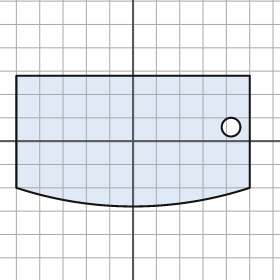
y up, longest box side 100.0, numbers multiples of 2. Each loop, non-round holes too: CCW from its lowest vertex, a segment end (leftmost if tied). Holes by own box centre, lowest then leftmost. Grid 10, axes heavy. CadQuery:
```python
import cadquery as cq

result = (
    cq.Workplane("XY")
    .moveTo(-50.0, -20.0)
    .threePointArc((0.0, -28.0), (50.0, -20.0))
    .lineTo(50.0, 28.0)
    .lineTo(-50.0, 28.0)
    .close()
    .moveTo(42.0, 6.0)
    .circle(4.0)
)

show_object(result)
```